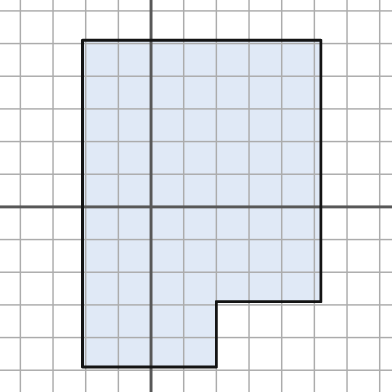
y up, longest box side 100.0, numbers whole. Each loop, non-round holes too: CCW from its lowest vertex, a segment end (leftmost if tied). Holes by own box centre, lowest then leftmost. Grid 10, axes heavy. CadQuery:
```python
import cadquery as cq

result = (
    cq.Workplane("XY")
    .moveTo(-21.0, -49.0)
    .lineTo(20.0, -49.0)
    .lineTo(20.0, -29.0)
    .lineTo(52.0, -29.0)
    .lineTo(52.0, 51.0)
    .lineTo(-21.0, 51.0)
    .close()
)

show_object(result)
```